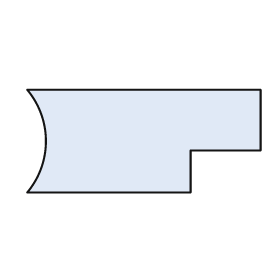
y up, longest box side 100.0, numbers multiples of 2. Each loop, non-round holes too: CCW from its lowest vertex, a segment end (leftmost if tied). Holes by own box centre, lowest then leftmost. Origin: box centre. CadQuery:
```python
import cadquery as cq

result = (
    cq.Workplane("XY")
    .moveTo(-50.0, -22.0)
    .lineTo(20.0, -22.0)
    .lineTo(20.0, -4.0)
    .lineTo(50.0, -4.0)
    .lineTo(50.0, 22.0)
    .lineTo(-50.0, 22.0)
    .threePointArc((-42.0, 0.0), (-50.0, -22.0))
    .close()
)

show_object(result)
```